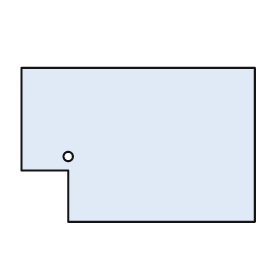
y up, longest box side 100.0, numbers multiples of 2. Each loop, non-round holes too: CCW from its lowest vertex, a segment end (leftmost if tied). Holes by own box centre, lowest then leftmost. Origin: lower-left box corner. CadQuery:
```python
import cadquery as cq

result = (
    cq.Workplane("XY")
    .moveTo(20.0, 0.0)
    .lineTo(100.0, 0.0)
    .lineTo(100.0, 66.0)
    .lineTo(0.0, 66.0)
    .lineTo(0.0, 22.0)
    .lineTo(20.0, 22.0)
    .close()
    .moveTo(20.0, 28.0)
    .circle(2.0)
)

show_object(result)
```